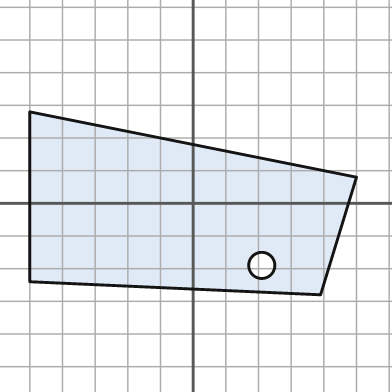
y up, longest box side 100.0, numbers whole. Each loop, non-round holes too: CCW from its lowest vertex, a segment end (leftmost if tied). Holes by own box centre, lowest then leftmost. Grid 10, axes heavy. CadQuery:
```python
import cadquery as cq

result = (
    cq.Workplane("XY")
    .moveTo(39.0, -28.0)
    .lineTo(50.0, 8.0)
    .lineTo(-50.0, 28.0)
    .lineTo(-50.0, -24.0)
    .close()
    .moveTo(21.0, -19.0)
    .circle(4.0)
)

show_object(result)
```